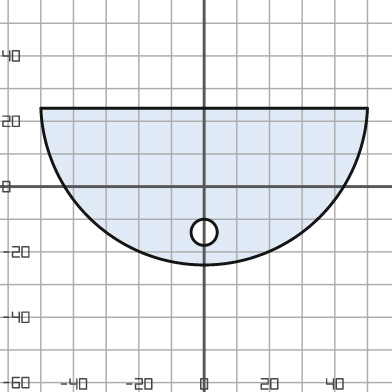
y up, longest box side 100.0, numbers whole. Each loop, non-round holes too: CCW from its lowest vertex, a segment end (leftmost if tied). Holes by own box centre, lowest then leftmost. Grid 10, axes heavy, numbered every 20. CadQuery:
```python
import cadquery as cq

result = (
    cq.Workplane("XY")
    .moveTo(-50.0, 24.0)
    .threePointArc((0.0, -24.0), (50.0, 24.0))
    .close()
    .moveTo(0.0, -14.0)
    .circle(4.0)
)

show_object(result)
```